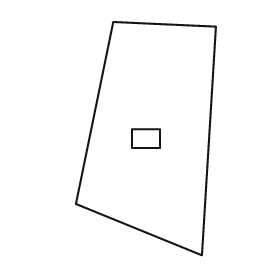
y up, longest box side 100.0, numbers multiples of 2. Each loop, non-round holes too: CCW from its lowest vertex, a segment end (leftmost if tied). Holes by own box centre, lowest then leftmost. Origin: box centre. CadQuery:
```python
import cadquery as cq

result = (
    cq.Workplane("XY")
    .moveTo(24.0, -50.0)
    .lineTo(30.0, 48.0)
    .lineTo(-14.0, 50.0)
    .lineTo(-30.0, -28.0)
    .close()
    .moveTo(-6.0, -4.0)
    .lineTo(6.0, -4.0)
    .lineTo(6.0, 4.0)
    .lineTo(-6.0, 4.0)
    .close()
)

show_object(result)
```